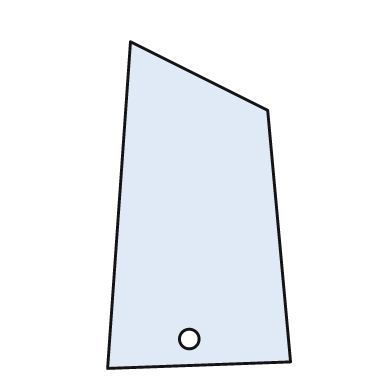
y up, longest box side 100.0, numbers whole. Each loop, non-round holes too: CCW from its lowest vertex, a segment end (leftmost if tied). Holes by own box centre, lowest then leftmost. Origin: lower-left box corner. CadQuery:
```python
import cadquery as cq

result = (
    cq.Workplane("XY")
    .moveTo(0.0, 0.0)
    .lineTo(56.0, 2.0)
    .lineTo(49.0, 79.0)
    .lineTo(7.0, 100.0)
    .close()
    .moveTo(25.0, 9.0)
    .circle(3.0)
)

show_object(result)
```